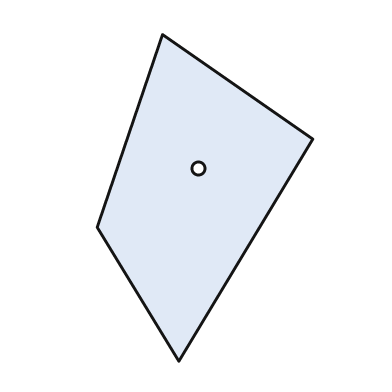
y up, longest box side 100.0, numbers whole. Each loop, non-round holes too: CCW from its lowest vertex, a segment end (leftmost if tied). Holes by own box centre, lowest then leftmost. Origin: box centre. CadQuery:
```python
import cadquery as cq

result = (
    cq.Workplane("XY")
    .moveTo(-8.0, -50.0)
    .lineTo(33.0, 18.0)
    .lineTo(-13.0, 50.0)
    .lineTo(-33.0, -9.0)
    .close()
    .moveTo(-2.0, 9.0)
    .circle(2.0)
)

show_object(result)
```